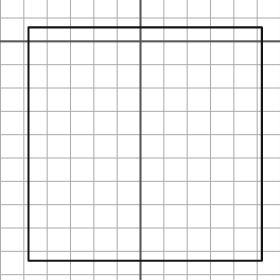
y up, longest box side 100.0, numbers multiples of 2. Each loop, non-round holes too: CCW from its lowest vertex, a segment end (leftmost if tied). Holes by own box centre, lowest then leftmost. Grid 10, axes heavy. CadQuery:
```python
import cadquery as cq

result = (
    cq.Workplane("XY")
    .moveTo(-48.0, -94.0)
    .lineTo(52.0, -94.0)
    .lineTo(52.0, 6.0)
    .lineTo(-48.0, 6.0)
    .close()
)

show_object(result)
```